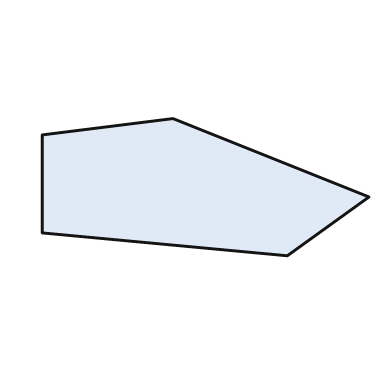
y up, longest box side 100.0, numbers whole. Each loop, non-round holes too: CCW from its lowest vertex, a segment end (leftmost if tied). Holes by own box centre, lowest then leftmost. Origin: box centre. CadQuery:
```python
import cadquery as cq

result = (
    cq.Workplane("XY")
    .moveTo(25.0, -21.0)
    .lineTo(50.0, -3.0)
    .lineTo(-10.0, 21.0)
    .lineTo(-50.0, 16.0)
    .lineTo(-50.0, -14.0)
    .close()
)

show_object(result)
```